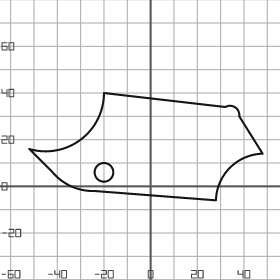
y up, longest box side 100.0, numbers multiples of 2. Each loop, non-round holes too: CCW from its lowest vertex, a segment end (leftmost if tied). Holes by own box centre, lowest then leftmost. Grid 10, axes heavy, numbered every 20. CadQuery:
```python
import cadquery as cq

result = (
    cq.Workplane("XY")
    .moveTo(28.0, -6.0)
    .threePointArc((34.0, 8.0), (48.0, 14.0))
    .lineTo(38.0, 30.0)
    .threePointArc((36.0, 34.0), (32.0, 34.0))
    .lineTo(-20.0, 40.0)
    .threePointArc((-30.0, 20.0), (-52.0, 16.0))
    .lineTo(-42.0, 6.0)
    .threePointArc((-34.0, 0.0), (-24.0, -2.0))
    .close()
    .moveTo(-20.0, 6.0)
    .circle(4.0)
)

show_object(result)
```